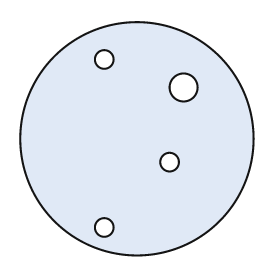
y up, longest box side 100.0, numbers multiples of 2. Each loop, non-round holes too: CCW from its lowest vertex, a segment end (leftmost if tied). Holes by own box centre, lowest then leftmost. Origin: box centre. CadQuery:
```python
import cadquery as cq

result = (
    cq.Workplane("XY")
    .moveTo(0.0, 0.0)
    .circle(50.0)
    .moveTo(-14.0, -38.0)
    .circle(4.0)
    .moveTo(14.0, -10.0)
    .circle(4.0)
    .moveTo(20.0, 22.0)
    .circle(6.0)
    .moveTo(-14.0, 34.0)
    .circle(4.0)
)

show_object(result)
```